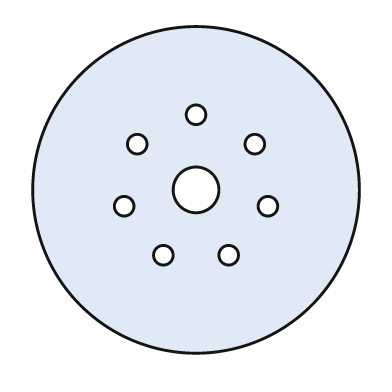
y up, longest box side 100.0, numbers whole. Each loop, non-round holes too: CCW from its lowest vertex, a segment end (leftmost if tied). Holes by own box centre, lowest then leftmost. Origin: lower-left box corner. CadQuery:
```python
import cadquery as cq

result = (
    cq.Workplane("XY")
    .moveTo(50.0, 50.0)
    .circle(50.0)
    .moveTo(40.0, 30.0)
    .circle(3.0)
    .moveTo(60.0, 30.0)
    .circle(3.0)
    .moveTo(28.0, 45.0)
    .circle(3.0)
    .moveTo(72.0, 45.0)
    .circle(3.0)
    .moveTo(50.0, 50.0)
    .circle(7.0)
    .moveTo(32.0, 64.0)
    .circle(3.0)
    .moveTo(68.0, 64.0)
    .circle(3.0)
    .moveTo(50.0, 73.0)
    .circle(3.0)
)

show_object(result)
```